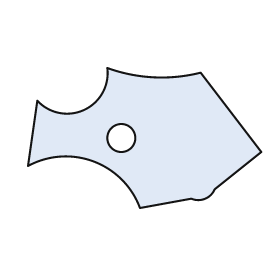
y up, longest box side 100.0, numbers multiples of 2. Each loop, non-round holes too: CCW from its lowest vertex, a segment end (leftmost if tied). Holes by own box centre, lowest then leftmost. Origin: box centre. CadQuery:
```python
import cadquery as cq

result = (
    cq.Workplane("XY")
    .moveTo(-2.0, -30.0)
    .lineTo(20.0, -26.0)
    .threePointArc((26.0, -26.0), (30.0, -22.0))
    .lineTo(50.0, -6.0)
    .lineTo(24.0, 28.0)
    .threePointArc((4.0, 26.0), (-16.0, 30.0))
    .threePointArc((-26.0, 12.0), (-46.0, 16.0))
    .lineTo(-50.0, -12.0)
    .threePointArc((-22.0, -10.0), (-2.0, -30.0))
    .close()
    .moveTo(-10.0, 0.0)
    .circle(6.0)
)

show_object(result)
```